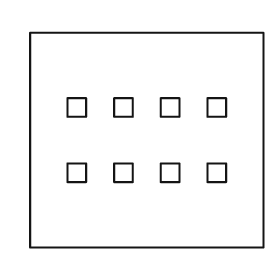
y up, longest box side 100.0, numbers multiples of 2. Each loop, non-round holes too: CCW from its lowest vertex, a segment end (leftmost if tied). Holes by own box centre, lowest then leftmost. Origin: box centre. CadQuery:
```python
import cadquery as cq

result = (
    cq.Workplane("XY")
    .moveTo(-50.0, -46.0)
    .lineTo(50.0, -46.0)
    .lineTo(50.0, 46.0)
    .lineTo(-50.0, 46.0)
    .close()
    .moveTo(-34.0, -18.0)
    .lineTo(-26.0, -18.0)
    .lineTo(-26.0, -10.0)
    .lineTo(-34.0, -10.0)
    .close()
    .moveTo(-14.0, -18.0)
    .lineTo(-6.0, -18.0)
    .lineTo(-6.0, -10.0)
    .lineTo(-14.0, -10.0)
    .close()
    .moveTo(6.0, -18.0)
    .lineTo(14.0, -18.0)
    .lineTo(14.0, -10.0)
    .lineTo(6.0, -10.0)
    .close()
    .moveTo(26.0, -18.0)
    .lineTo(34.0, -18.0)
    .lineTo(34.0, -10.0)
    .lineTo(26.0, -10.0)
    .close()
    .moveTo(-34.0, 10.0)
    .lineTo(-26.0, 10.0)
    .lineTo(-26.0, 18.0)
    .lineTo(-34.0, 18.0)
    .close()
    .moveTo(-14.0, 10.0)
    .lineTo(-6.0, 10.0)
    .lineTo(-6.0, 18.0)
    .lineTo(-14.0, 18.0)
    .close()
    .moveTo(6.0, 10.0)
    .lineTo(14.0, 10.0)
    .lineTo(14.0, 18.0)
    .lineTo(6.0, 18.0)
    .close()
    .moveTo(26.0, 10.0)
    .lineTo(34.0, 10.0)
    .lineTo(34.0, 18.0)
    .lineTo(26.0, 18.0)
    .close()
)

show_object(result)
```